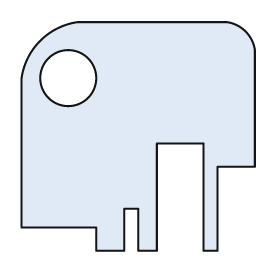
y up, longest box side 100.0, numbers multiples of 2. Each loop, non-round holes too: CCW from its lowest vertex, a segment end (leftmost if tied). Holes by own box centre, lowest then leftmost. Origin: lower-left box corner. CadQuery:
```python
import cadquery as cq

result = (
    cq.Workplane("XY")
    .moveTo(32.0, 0.0)
    .lineTo(44.0, 0.0)
    .lineTo(44.0, 18.0)
    .lineTo(50.0, 18.0)
    .lineTo(50.0, 0.0)
    .lineTo(58.0, 0.0)
    .lineTo(58.0, 46.0)
    .lineTo(78.0, 46.0)
    .lineTo(78.0, 0.0)
    .lineTo(84.0, 0.0)
    .lineTo(84.0, 36.0)
    .lineTo(100.0, 36.0)
    .lineTo(100.0, 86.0)
    .threePointArc((96.0, 94.0), (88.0, 98.0))
    .lineTo(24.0, 98.0)
    .threePointArc((8.0, 90.0), (0.0, 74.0))
    .lineTo(0.0, 10.0)
    .lineTo(32.0, 10.0)
    .close()
    .moveTo(20.0, 74.0)
    .circle(12.0)
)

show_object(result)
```